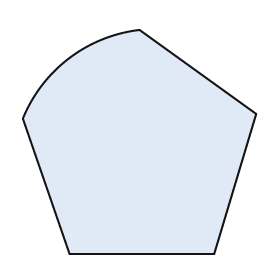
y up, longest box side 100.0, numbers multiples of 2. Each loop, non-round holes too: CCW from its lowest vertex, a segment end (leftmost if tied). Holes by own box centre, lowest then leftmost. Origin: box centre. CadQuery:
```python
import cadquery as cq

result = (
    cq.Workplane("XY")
    .moveTo(-30.0, -48.0)
    .lineTo(32.0, -48.0)
    .lineTo(50.0, 12.0)
    .lineTo(0.0, 48.0)
    .threePointArc((-30.0, 36.0), (-50.0, 10.0))
    .close()
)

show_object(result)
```